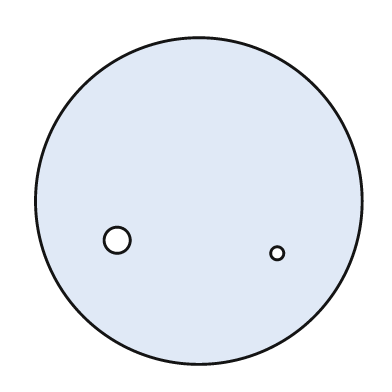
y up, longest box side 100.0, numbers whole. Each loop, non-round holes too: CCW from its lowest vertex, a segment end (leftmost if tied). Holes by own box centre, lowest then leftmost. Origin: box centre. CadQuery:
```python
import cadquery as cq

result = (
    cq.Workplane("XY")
    .moveTo(0.0, 0.0)
    .circle(50.0)
    .moveTo(24.0, -16.0)
    .circle(2.0)
    .moveTo(-25.0, -12.0)
    .circle(4.0)
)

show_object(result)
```